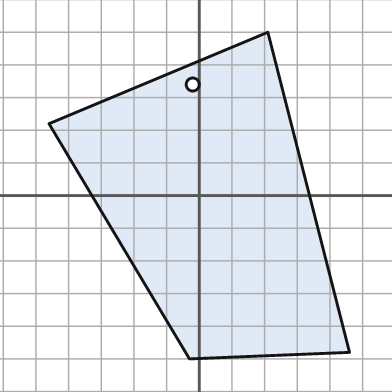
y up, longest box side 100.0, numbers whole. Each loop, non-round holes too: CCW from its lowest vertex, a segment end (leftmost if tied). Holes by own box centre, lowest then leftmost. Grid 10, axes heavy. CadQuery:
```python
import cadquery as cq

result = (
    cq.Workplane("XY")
    .moveTo(-3.0, -50.0)
    .lineTo(46.0, -48.0)
    .lineTo(21.0, 50.0)
    .lineTo(-46.0, 22.0)
    .close()
    .moveTo(-2.0, 34.0)
    .circle(2.0)
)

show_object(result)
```